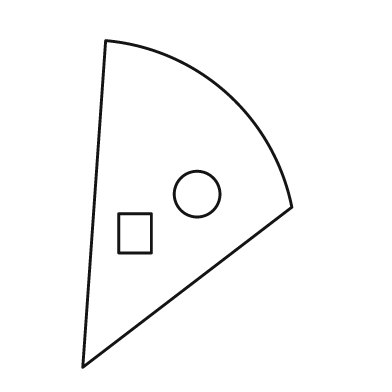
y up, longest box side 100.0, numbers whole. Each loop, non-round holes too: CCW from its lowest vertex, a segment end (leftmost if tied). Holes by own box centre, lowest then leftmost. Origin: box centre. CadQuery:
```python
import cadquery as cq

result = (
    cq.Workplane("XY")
    .moveTo(-32.0, -50.0)
    .lineTo(32.0, -1.0)
    .threePointArc((12.0, 34.0), (-25.0, 50.0))
    .close()
    .moveTo(-21.0, -15.0)
    .lineTo(-11.0, -15.0)
    .lineTo(-11.0, -3.0)
    .lineTo(-21.0, -3.0)
    .close()
    .moveTo(3.0, 3.0)
    .circle(7.0)
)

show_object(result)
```